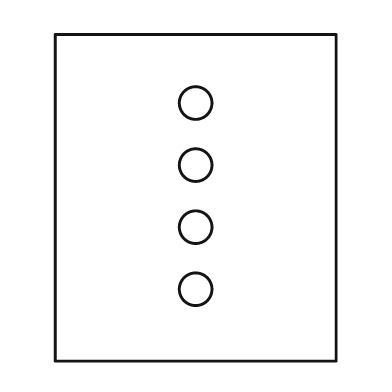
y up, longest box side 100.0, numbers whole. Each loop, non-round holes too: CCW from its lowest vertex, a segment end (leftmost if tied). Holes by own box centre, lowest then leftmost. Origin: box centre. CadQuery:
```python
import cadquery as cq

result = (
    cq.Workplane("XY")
    .moveTo(-43.0, -50.0)
    .lineTo(43.0, -50.0)
    .lineTo(43.0, 50.0)
    .lineTo(-43.0, 50.0)
    .close()
    .moveTo(0.0, -28.0)
    .circle(5.0)
    .moveTo(0.0, -9.0)
    .circle(5.0)
    .moveTo(0.0, 10.0)
    .circle(5.0)
    .moveTo(0.0, 29.0)
    .circle(5.0)
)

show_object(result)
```